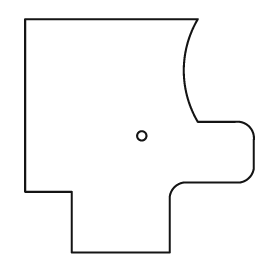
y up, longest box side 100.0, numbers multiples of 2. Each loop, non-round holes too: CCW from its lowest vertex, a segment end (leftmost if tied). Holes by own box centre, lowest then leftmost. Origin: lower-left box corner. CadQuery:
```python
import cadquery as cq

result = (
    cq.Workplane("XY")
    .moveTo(20.0, 0.0)
    .lineTo(62.0, 0.0)
    .lineTo(62.0, 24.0)
    .threePointArc((64.0, 28.0), (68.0, 30.0))
    .lineTo(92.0, 30.0)
    .threePointArc((96.0, 32.0), (98.0, 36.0))
    .lineTo(98.0, 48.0)
    .threePointArc((96.0, 54.0), (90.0, 56.0))
    .lineTo(74.0, 56.0)
    .threePointArc((68.0, 78.0), (74.0, 100.0))
    .lineTo(0.0, 100.0)
    .lineTo(0.0, 26.0)
    .lineTo(20.0, 26.0)
    .close()
    .moveTo(50.0, 50.0)
    .circle(2.0)
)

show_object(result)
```